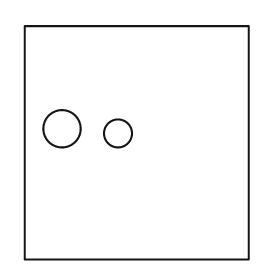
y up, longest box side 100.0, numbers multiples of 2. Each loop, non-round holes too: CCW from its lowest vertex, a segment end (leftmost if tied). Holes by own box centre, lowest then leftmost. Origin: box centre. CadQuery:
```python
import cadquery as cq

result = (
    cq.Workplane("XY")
    .moveTo(-48.0, -50.0)
    .lineTo(48.0, -50.0)
    .lineTo(48.0, 50.0)
    .lineTo(-48.0, 50.0)
    .close()
    .moveTo(-8.0, 4.0)
    .circle(6.0)
    .moveTo(-32.0, 6.0)
    .circle(8.0)
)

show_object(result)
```